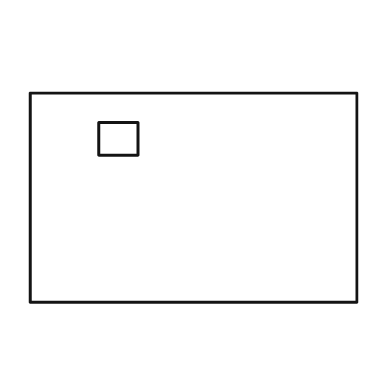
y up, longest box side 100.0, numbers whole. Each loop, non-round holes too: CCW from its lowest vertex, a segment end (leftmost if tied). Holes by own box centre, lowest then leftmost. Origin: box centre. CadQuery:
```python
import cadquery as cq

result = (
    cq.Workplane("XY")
    .moveTo(-50.0, -32.0)
    .lineTo(50.0, -32.0)
    .lineTo(50.0, 32.0)
    .lineTo(-50.0, 32.0)
    .close()
    .moveTo(-29.0, 13.0)
    .lineTo(-17.0, 13.0)
    .lineTo(-17.0, 23.0)
    .lineTo(-29.0, 23.0)
    .close()
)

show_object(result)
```